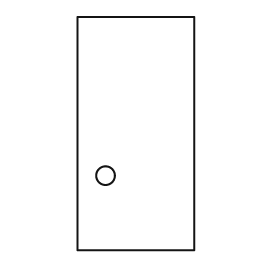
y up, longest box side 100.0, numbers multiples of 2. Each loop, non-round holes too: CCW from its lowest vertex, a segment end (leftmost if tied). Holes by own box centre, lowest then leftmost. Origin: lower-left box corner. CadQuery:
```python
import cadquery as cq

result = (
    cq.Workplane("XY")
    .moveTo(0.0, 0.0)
    .lineTo(50.0, 0.0)
    .lineTo(50.0, 100.0)
    .lineTo(0.0, 100.0)
    .close()
    .moveTo(12.0, 32.0)
    .circle(4.0)
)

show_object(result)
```